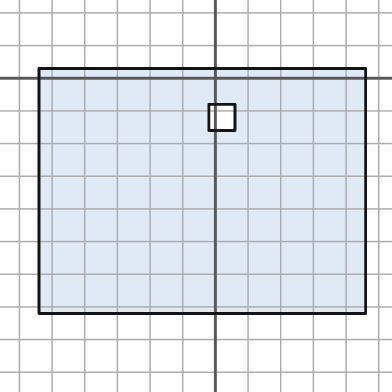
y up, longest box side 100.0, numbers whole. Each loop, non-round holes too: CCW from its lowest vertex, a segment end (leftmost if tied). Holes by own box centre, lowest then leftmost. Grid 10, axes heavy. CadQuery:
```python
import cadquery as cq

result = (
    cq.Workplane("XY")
    .moveTo(-54.0, -72.0)
    .lineTo(46.0, -72.0)
    .lineTo(46.0, 3.0)
    .lineTo(-54.0, 3.0)
    .close()
    .moveTo(-2.0, -16.0)
    .lineTo(6.0, -16.0)
    .lineTo(6.0, -8.0)
    .lineTo(-2.0, -8.0)
    .close()
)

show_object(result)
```